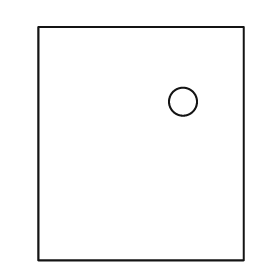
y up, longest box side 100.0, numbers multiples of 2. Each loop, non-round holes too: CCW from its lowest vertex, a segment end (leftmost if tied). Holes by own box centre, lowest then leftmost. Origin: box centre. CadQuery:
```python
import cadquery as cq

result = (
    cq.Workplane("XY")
    .moveTo(-44.0, -50.0)
    .lineTo(44.0, -50.0)
    .lineTo(44.0, 50.0)
    .lineTo(-44.0, 50.0)
    .close()
    .moveTo(18.0, 18.0)
    .circle(6.0)
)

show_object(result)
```